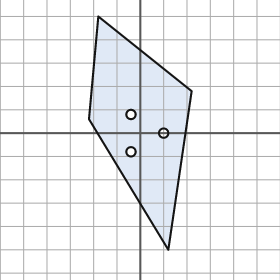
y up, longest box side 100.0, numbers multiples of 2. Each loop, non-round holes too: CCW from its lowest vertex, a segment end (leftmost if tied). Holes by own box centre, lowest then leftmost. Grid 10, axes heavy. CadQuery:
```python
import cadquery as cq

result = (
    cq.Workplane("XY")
    .moveTo(12.0, -50.0)
    .lineTo(22.0, 18.0)
    .lineTo(-18.0, 50.0)
    .lineTo(-22.0, 6.0)
    .close()
    .moveTo(-4.0, -8.0)
    .circle(2.0)
    .moveTo(10.0, 0.0)
    .circle(2.0)
    .moveTo(-4.0, 8.0)
    .circle(2.0)
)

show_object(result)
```